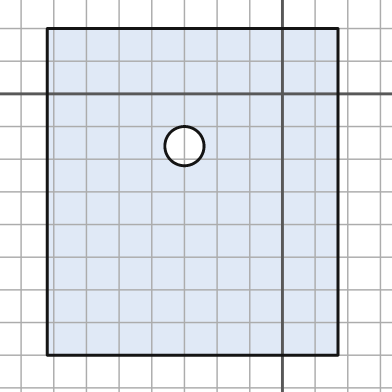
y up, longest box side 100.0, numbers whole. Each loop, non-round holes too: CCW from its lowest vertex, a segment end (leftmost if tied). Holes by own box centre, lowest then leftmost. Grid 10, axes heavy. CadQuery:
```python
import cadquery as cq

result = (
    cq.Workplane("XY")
    .moveTo(-72.0, -80.0)
    .lineTo(17.0, -80.0)
    .lineTo(17.0, 20.0)
    .lineTo(-72.0, 20.0)
    .close()
    .moveTo(-30.0, -16.0)
    .circle(6.0)
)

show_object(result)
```